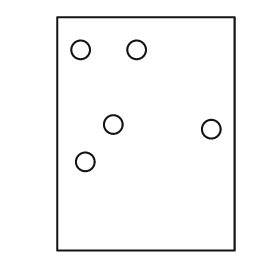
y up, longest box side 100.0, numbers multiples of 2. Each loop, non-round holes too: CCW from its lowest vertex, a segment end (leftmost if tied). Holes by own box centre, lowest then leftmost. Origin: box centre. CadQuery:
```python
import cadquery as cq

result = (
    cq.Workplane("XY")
    .moveTo(-38.0, -50.0)
    .lineTo(38.0, -50.0)
    .lineTo(38.0, 50.0)
    .lineTo(-38.0, 50.0)
    .close()
    .moveTo(-26.0, -12.0)
    .circle(4.0)
    .moveTo(28.0, 2.0)
    .circle(4.0)
    .moveTo(-14.0, 4.0)
    .circle(4.0)
    .moveTo(-28.0, 36.0)
    .circle(4.0)
    .moveTo(-4.0, 36.0)
    .circle(4.0)
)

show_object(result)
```